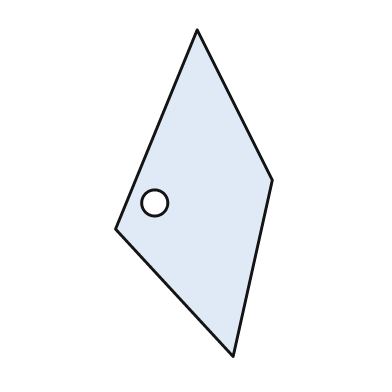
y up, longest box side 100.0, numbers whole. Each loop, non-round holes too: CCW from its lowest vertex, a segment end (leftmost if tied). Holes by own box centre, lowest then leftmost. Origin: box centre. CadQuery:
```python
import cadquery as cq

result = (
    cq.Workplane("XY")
    .moveTo(12.0, -50.0)
    .lineTo(24.0, 4.0)
    .lineTo(1.0, 50.0)
    .lineTo(-24.0, -11.0)
    .close()
    .moveTo(-12.0, -3.0)
    .circle(4.0)
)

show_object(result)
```